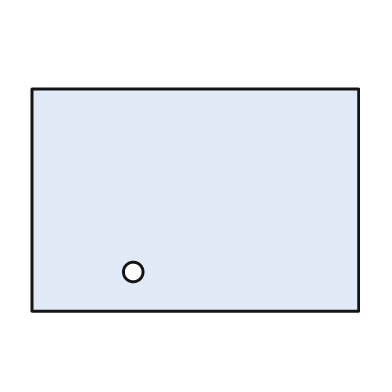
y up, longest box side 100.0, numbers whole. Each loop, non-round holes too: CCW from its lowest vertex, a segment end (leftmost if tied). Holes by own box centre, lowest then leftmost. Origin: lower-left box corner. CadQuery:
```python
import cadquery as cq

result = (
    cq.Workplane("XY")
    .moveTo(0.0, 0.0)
    .lineTo(100.0, 0.0)
    .lineTo(100.0, 68.0)
    .lineTo(0.0, 68.0)
    .close()
    .moveTo(31.0, 12.0)
    .circle(3.0)
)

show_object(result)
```